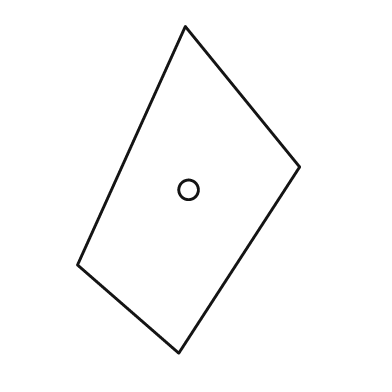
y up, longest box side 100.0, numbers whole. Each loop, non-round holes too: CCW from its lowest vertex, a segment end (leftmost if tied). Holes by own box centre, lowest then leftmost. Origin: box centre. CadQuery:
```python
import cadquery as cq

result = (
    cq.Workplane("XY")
    .moveTo(-3.0, -50.0)
    .lineTo(34.0, 7.0)
    .lineTo(-1.0, 50.0)
    .lineTo(-34.0, -23.0)
    .close()
    .moveTo(0.0, 0.0)
    .circle(3.0)
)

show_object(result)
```